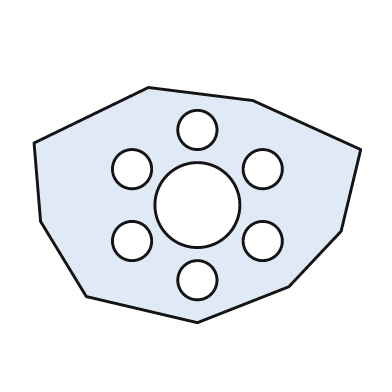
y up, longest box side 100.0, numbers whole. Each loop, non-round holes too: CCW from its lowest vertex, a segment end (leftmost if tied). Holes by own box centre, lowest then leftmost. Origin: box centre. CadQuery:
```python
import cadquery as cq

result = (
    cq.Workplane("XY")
    .moveTo(0.0, -36.0)
    .lineTo(28.0, -25.0)
    .lineTo(44.0, -8.0)
    .lineTo(50.0, 17.0)
    .lineTo(17.0, 32.0)
    .lineTo(-15.0, 36.0)
    .lineTo(-50.0, 19.0)
    .lineTo(-48.0, -5.0)
    .lineTo(-34.0, -28.0)
    .close()
    .moveTo(0.0, -23.0)
    .circle(6.0)
    .moveTo(-20.0, -11.0)
    .circle(6.0)
    .moveTo(20.0, -11.0)
    .circle(6.0)
    .moveTo(0.0, 0.0)
    .circle(13.0)
    .moveTo(-20.0, 11.0)
    .circle(6.0)
    .moveTo(20.0, 11.0)
    .circle(6.0)
    .moveTo(0.0, 23.0)
    .circle(6.0)
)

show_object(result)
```